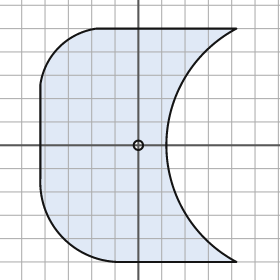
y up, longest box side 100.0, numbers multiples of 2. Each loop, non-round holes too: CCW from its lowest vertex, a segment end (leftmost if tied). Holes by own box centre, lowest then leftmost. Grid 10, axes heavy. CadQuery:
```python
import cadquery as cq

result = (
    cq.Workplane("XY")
    .moveTo(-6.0, -50.0)
    .lineTo(42.0, -50.0)
    .threePointArc((12.0, 0.0), (42.0, 50.0))
    .lineTo(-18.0, 50.0)
    .threePointArc((-34.0, 42.0), (-42.0, 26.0))
    .lineTo(-42.0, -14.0)
    .threePointArc((-32.0, -40.0), (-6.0, -50.0))
    .close()
    .moveTo(0.0, 0.0)
    .circle(2.0)
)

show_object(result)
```